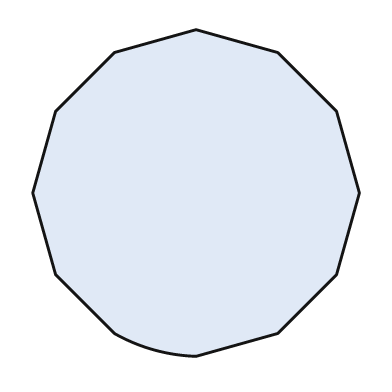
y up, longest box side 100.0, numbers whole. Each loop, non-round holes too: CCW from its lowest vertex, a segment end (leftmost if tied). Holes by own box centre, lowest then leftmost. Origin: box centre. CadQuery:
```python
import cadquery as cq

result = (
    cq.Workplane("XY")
    .moveTo(0.0, -50.0)
    .lineTo(25.0, -43.0)
    .lineTo(43.0, -25.0)
    .lineTo(50.0, 0.0)
    .lineTo(43.0, 25.0)
    .lineTo(25.0, 43.0)
    .lineTo(0.0, 50.0)
    .lineTo(-25.0, 43.0)
    .lineTo(-43.0, 25.0)
    .lineTo(-50.0, 0.0)
    .lineTo(-43.0, -25.0)
    .lineTo(-25.0, -43.0)
    .threePointArc((-13.0, -48.0), (0.0, -50.0))
    .close()
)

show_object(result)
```